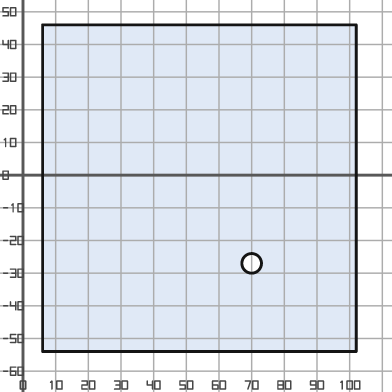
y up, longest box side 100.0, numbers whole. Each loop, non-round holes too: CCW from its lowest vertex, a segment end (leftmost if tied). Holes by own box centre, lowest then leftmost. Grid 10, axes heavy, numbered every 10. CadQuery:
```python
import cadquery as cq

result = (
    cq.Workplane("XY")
    .moveTo(6.0, -54.0)
    .lineTo(102.0, -54.0)
    .lineTo(102.0, 46.0)
    .lineTo(6.0, 46.0)
    .close()
    .moveTo(70.0, -27.0)
    .circle(3.0)
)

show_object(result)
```